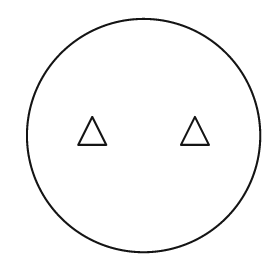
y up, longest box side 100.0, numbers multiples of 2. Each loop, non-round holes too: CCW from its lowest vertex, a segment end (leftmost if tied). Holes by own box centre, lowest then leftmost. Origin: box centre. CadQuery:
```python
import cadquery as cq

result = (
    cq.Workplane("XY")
    .moveTo(0.0, 0.0)
    .circle(50.0)
    .moveTo(-28.0, -4.0)
    .lineTo(-16.0, -4.0)
    .lineTo(-22.0, 8.0)
    .close()
    .moveTo(16.0, -4.0)
    .lineTo(28.0, -4.0)
    .lineTo(22.0, 8.0)
    .close()
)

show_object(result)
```